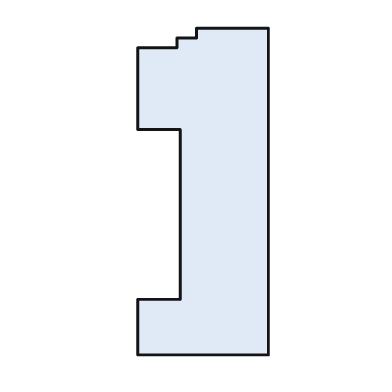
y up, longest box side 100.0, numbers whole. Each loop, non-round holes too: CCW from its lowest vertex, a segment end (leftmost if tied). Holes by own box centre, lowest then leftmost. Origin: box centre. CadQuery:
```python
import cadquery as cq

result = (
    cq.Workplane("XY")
    .moveTo(-20.0, -50.0)
    .lineTo(20.0, -50.0)
    .lineTo(20.0, 50.0)
    .lineTo(-2.0, 50.0)
    .lineTo(-2.0, 47.0)
    .lineTo(-8.0, 47.0)
    .lineTo(-8.0, 44.0)
    .lineTo(-20.0, 44.0)
    .lineTo(-20.0, 19.0)
    .lineTo(-7.0, 19.0)
    .lineTo(-7.0, -33.0)
    .lineTo(-20.0, -33.0)
    .close()
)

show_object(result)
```